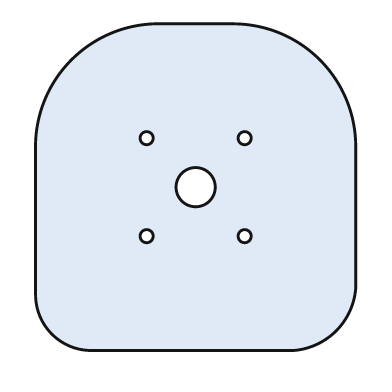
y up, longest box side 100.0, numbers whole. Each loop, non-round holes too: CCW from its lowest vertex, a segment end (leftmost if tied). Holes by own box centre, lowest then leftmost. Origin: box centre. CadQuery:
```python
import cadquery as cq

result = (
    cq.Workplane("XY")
    .moveTo(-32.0, -50.0)
    .lineTo(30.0, -50.0)
    .threePointArc((43.0, -44.0), (49.0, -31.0))
    .lineTo(49.0, 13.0)
    .threePointArc((38.0, 39.0), (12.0, 50.0))
    .lineTo(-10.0, 50.0)
    .threePointArc((-38.0, 39.0), (-49.0, 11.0))
    .lineTo(-49.0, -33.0)
    .threePointArc((-44.0, -45.0), (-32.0, -50.0))
    .close()
    .moveTo(-15.0, -15.0)
    .circle(2.0)
    .moveTo(15.0, -15.0)
    .circle(2.0)
    .moveTo(0.0, 0.0)
    .circle(6.0)
    .moveTo(-15.0, 15.0)
    .circle(2.0)
    .moveTo(15.0, 15.0)
    .circle(2.0)
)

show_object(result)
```